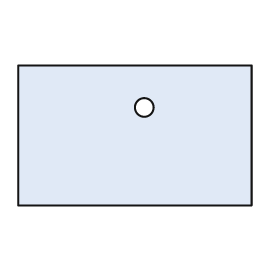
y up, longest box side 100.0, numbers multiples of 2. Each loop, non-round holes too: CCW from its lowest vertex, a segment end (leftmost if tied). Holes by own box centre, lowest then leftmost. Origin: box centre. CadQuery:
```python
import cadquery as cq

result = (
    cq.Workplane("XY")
    .moveTo(-50.0, -30.0)
    .lineTo(50.0, -30.0)
    .lineTo(50.0, 30.0)
    .lineTo(-50.0, 30.0)
    .close()
    .moveTo(4.0, 12.0)
    .circle(4.0)
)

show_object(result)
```